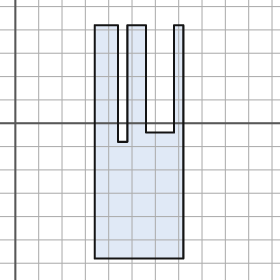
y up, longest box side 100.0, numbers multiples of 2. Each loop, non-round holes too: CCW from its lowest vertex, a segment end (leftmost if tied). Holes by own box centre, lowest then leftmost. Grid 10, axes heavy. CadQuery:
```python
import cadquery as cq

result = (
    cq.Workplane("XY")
    .moveTo(34.0, -58.0)
    .lineTo(72.0, -58.0)
    .lineTo(72.0, 42.0)
    .lineTo(68.0, 42.0)
    .lineTo(68.0, -4.0)
    .lineTo(56.0, -4.0)
    .lineTo(56.0, 42.0)
    .lineTo(48.0, 42.0)
    .lineTo(48.0, -8.0)
    .lineTo(44.0, -8.0)
    .lineTo(44.0, 42.0)
    .lineTo(34.0, 42.0)
    .close()
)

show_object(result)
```